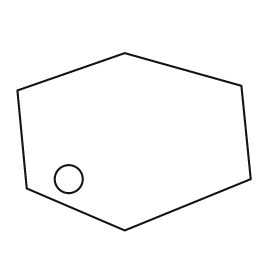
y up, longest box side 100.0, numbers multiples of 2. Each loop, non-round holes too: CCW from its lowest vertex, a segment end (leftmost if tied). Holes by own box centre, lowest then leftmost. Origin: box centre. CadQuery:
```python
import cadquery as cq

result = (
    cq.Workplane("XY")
    .moveTo(-4.0, -38.0)
    .lineTo(50.0, -16.0)
    .lineTo(46.0, 24.0)
    .lineTo(-4.0, 38.0)
    .lineTo(-50.0, 22.0)
    .lineTo(-46.0, -20.0)
    .close()
    .moveTo(-28.0, -16.0)
    .circle(6.0)
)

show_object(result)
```